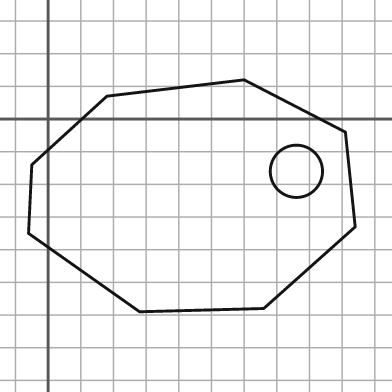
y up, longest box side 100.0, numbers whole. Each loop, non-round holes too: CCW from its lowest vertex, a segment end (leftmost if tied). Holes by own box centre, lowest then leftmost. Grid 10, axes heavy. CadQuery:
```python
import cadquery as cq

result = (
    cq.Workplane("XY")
    .moveTo(28.0, -59.0)
    .lineTo(66.0, -58.0)
    .lineTo(94.0, -33.0)
    .lineTo(91.0, -4.0)
    .lineTo(60.0, 12.0)
    .lineTo(18.0, 7.0)
    .lineTo(-5.0, -14.0)
    .lineTo(-6.0, -35.0)
    .close()
    .moveTo(76.0, -16.0)
    .circle(8.0)
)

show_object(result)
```